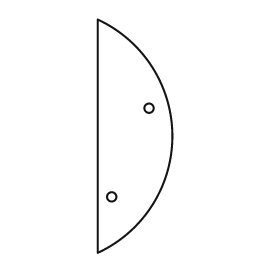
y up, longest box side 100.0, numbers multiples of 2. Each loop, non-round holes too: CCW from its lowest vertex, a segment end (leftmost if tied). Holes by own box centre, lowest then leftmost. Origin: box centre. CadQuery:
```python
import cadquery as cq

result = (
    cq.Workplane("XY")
    .moveTo(-16.0, -50.0)
    .threePointArc((16.0, 0.0), (-16.0, 50.0))
    .close()
    .moveTo(-10.0, -26.0)
    .circle(2.0)
    .moveTo(6.0, 12.0)
    .circle(2.0)
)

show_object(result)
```